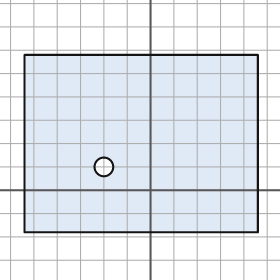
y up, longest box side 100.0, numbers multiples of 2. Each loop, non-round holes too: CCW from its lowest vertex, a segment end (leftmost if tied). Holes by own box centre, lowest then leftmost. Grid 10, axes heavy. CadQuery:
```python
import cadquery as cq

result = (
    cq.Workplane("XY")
    .moveTo(-54.0, -18.0)
    .lineTo(46.0, -18.0)
    .lineTo(46.0, 58.0)
    .lineTo(-54.0, 58.0)
    .close()
    .moveTo(-20.0, 10.0)
    .circle(4.0)
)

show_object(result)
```